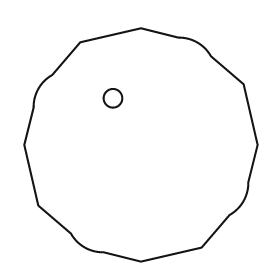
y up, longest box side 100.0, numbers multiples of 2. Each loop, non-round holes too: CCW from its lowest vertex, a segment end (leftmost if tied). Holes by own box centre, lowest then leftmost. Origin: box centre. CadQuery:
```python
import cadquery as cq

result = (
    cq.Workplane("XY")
    .moveTo(0.0, -50.0)
    .lineTo(26.0, -44.0)
    .lineTo(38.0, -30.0)
    .threePointArc((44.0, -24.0), (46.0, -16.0))
    .lineTo(50.0, 0.0)
    .lineTo(44.0, 26.0)
    .lineTo(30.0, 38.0)
    .threePointArc((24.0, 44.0), (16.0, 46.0))
    .lineTo(0.0, 50.0)
    .lineTo(-26.0, 44.0)
    .lineTo(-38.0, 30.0)
    .threePointArc((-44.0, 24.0), (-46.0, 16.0))
    .lineTo(-50.0, 0.0)
    .lineTo(-44.0, -26.0)
    .lineTo(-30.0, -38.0)
    .threePointArc((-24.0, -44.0), (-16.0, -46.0))
    .close()
    .moveTo(-12.0, 20.0)
    .circle(4.0)
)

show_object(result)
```